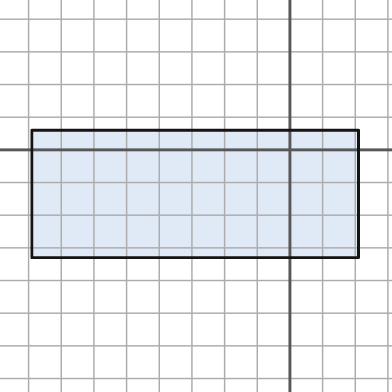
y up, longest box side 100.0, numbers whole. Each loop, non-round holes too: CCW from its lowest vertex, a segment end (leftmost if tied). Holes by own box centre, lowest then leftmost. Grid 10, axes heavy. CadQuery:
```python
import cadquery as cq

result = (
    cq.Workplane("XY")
    .moveTo(-79.0, -33.0)
    .lineTo(21.0, -33.0)
    .lineTo(21.0, 6.0)
    .lineTo(-79.0, 6.0)
    .close()
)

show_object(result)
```